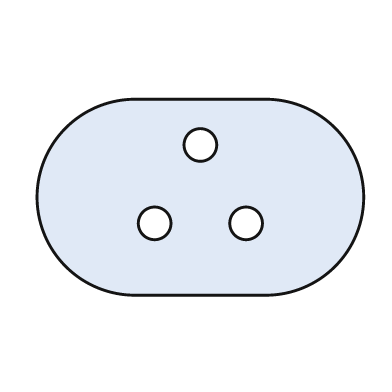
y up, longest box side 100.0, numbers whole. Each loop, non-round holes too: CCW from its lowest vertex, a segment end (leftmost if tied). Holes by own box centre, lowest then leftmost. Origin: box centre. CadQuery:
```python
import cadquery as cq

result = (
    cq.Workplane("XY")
    .moveTo(-20.0, -30.0)
    .lineTo(20.0, -30.0)
    .threePointArc((50.0, 0.0), (20.0, 30.0))
    .lineTo(-20.0, 30.0)
    .threePointArc((-50.0, 0.0), (-20.0, -30.0))
    .close()
    .moveTo(-14.0, -8.0)
    .circle(5.0)
    .moveTo(14.0, -8.0)
    .circle(5.0)
    .moveTo(0.0, 16.0)
    .circle(5.0)
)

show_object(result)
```